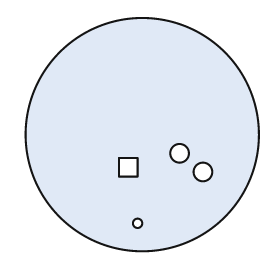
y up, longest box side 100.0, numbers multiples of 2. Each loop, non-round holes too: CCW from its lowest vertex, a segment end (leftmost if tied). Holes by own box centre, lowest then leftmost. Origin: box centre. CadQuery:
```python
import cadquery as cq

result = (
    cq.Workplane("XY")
    .moveTo(0.0, 0.0)
    .circle(50.0)
    .moveTo(-2.0, -38.0)
    .circle(2.0)
    .moveTo(26.0, -16.0)
    .circle(4.0)
    .moveTo(-10.0, -18.0)
    .lineTo(-2.0, -18.0)
    .lineTo(-2.0, -10.0)
    .lineTo(-10.0, -10.0)
    .close()
    .moveTo(16.0, -8.0)
    .circle(4.0)
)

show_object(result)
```